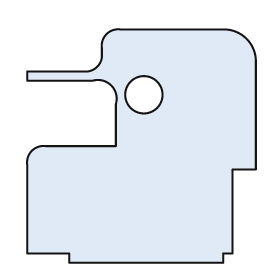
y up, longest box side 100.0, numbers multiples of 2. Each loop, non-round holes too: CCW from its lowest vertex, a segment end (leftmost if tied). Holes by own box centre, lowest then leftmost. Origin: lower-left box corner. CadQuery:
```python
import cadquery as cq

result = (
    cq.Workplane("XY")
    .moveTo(18.0, 0.0)
    .lineTo(84.0, 0.0)
    .lineTo(84.0, 4.0)
    .lineTo(88.0, 4.0)
    .lineTo(88.0, 40.0)
    .lineTo(98.0, 40.0)
    .lineTo(98.0, 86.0)
    .threePointArc((94.0, 96.0), (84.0, 100.0))
    .lineTo(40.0, 100.0)
    .threePointArc((34.0, 98.0), (32.0, 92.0))
    .lineTo(32.0, 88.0)
    .threePointArc((30.0, 84.0), (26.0, 82.0))
    .lineTo(0.0, 82.0)
    .lineTo(0.0, 78.0)
    .lineTo(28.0, 78.0)
    .threePointArc((36.0, 76.0), (38.0, 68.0))
    .lineTo(38.0, 50.0)
    .lineTo(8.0, 50.0)
    .threePointArc((2.0, 48.0), (0.0, 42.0))
    .lineTo(0.0, 4.0)
    .lineTo(18.0, 4.0)
    .close()
    .moveTo(50.0, 72.0)
    .circle(8.0)
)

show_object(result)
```